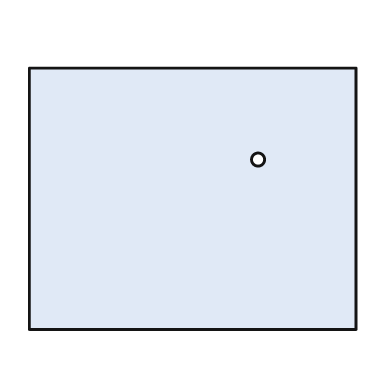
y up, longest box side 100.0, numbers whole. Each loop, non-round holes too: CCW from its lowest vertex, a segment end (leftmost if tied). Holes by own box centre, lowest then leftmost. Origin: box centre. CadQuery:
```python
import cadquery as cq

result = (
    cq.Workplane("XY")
    .moveTo(-50.0, -40.0)
    .lineTo(50.0, -40.0)
    .lineTo(50.0, 40.0)
    .lineTo(-50.0, 40.0)
    .close()
    .moveTo(20.0, 12.0)
    .circle(2.0)
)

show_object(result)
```